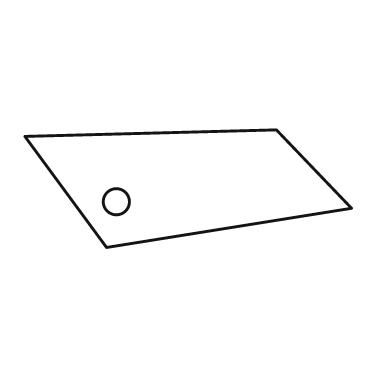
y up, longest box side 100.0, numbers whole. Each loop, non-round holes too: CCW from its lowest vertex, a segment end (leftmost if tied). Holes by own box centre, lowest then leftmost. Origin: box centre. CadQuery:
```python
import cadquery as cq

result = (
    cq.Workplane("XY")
    .moveTo(-25.0, -18.0)
    .lineTo(50.0, -6.0)
    .lineTo(27.0, 18.0)
    .lineTo(-50.0, 16.0)
    .close()
    .moveTo(-22.0, -4.0)
    .circle(4.0)
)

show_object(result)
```